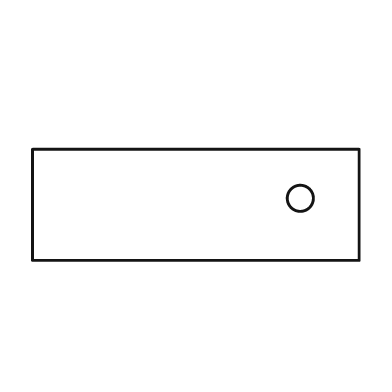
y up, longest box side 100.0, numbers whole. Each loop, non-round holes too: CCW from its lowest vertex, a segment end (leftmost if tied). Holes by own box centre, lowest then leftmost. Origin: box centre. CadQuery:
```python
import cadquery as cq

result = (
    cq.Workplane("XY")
    .moveTo(-50.0, -17.0)
    .lineTo(50.0, -17.0)
    .lineTo(50.0, 17.0)
    .lineTo(-50.0, 17.0)
    .close()
    .moveTo(32.0, 2.0)
    .circle(4.0)
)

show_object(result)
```